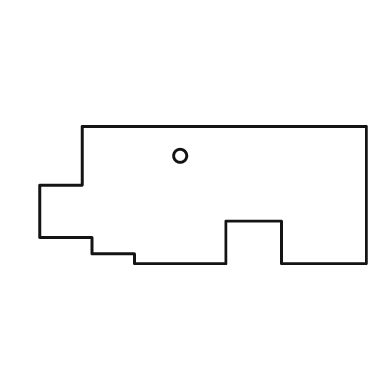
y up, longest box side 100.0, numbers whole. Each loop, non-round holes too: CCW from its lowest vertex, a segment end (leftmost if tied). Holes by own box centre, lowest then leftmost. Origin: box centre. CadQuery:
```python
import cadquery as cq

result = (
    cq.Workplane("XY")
    .moveTo(-21.0, -21.0)
    .lineTo(7.0, -21.0)
    .lineTo(7.0, -8.0)
    .lineTo(24.0, -8.0)
    .lineTo(24.0, -21.0)
    .lineTo(50.0, -21.0)
    .lineTo(50.0, 21.0)
    .lineTo(-37.0, 21.0)
    .lineTo(-37.0, 3.0)
    .lineTo(-50.0, 3.0)
    .lineTo(-50.0, -13.0)
    .lineTo(-34.0, -13.0)
    .lineTo(-34.0, -18.0)
    .lineTo(-21.0, -18.0)
    .close()
    .moveTo(-7.0, 12.0)
    .circle(2.0)
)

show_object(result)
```